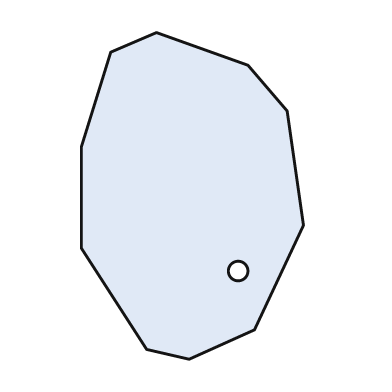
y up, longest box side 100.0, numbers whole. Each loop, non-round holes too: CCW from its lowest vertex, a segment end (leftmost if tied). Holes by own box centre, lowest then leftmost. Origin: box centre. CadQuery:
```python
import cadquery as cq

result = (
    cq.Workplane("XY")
    .moveTo(-1.0, -50.0)
    .lineTo(19.0, -41.0)
    .lineTo(34.0, -9.0)
    .lineTo(29.0, 26.0)
    .lineTo(17.0, 40.0)
    .lineTo(-11.0, 50.0)
    .lineTo(-25.0, 44.0)
    .lineTo(-34.0, 15.0)
    .lineTo(-34.0, -16.0)
    .lineTo(-14.0, -47.0)
    .close()
    .moveTo(14.0, -23.0)
    .circle(3.0)
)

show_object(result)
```